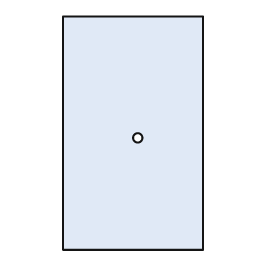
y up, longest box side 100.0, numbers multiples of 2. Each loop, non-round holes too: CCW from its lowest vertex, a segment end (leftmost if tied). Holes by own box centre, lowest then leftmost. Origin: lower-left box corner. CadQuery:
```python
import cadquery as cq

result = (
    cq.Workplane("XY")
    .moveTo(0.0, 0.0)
    .lineTo(60.0, 0.0)
    .lineTo(60.0, 100.0)
    .lineTo(0.0, 100.0)
    .close()
    .moveTo(32.0, 48.0)
    .circle(2.0)
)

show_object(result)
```